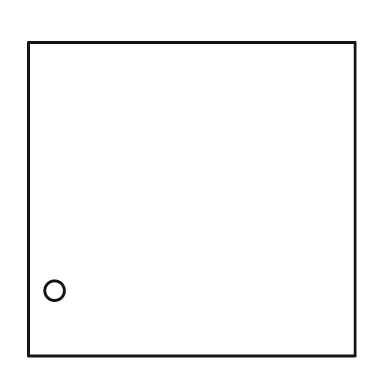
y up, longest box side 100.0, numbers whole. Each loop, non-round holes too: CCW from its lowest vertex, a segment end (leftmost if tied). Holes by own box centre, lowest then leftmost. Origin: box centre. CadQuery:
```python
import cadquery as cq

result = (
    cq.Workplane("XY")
    .moveTo(-50.0, -48.0)
    .lineTo(50.0, -48.0)
    .lineTo(50.0, 48.0)
    .lineTo(-50.0, 48.0)
    .close()
    .moveTo(-42.0, -28.0)
    .circle(3.0)
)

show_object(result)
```